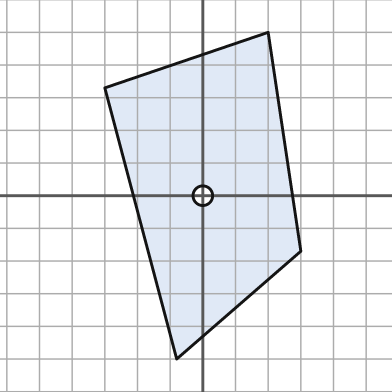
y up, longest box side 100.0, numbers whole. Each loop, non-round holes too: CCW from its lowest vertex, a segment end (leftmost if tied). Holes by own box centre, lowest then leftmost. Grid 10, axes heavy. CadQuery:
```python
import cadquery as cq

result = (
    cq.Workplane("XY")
    .moveTo(-8.0, -50.0)
    .lineTo(30.0, -17.0)
    .lineTo(20.0, 50.0)
    .lineTo(-30.0, 33.0)
    .close()
    .moveTo(0.0, 0.0)
    .circle(3.0)
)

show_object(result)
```